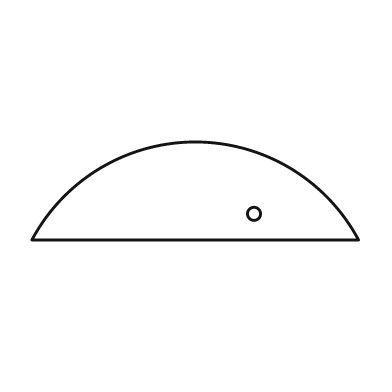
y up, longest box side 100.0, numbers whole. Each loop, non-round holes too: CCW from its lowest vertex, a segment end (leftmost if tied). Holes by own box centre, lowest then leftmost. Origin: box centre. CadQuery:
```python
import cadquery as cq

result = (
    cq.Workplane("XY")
    .moveTo(-50.0, -15.0)
    .lineTo(50.0, -15.0)
    .threePointArc((0.0, 15.0), (-50.0, -15.0))
    .close()
    .moveTo(18.0, -7.0)
    .circle(2.0)
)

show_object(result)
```